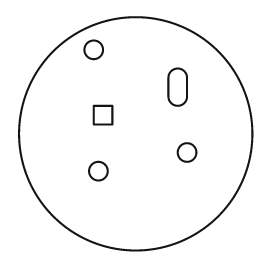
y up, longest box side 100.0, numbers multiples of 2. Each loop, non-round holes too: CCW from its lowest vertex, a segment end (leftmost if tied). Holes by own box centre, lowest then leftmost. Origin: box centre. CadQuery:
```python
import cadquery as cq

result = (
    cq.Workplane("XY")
    .moveTo(0.0, 0.0)
    .circle(50.0)
    .moveTo(-16.0, -16.0)
    .circle(4.0)
    .moveTo(22.0, -8.0)
    .circle(4.0)
    .moveTo(-18.0, 4.0)
    .lineTo(-10.0, 4.0)
    .lineTo(-10.0, 12.0)
    .lineTo(-18.0, 12.0)
    .close()
    .moveTo(14.0, 16.0)
    .threePointArc((18.0, 12.0), (22.0, 16.0))
    .lineTo(22.0, 24.0)
    .threePointArc((18.0, 28.0), (14.0, 24.0))
    .close()
    .moveTo(-18.0, 36.0)
    .circle(4.0)
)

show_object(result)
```